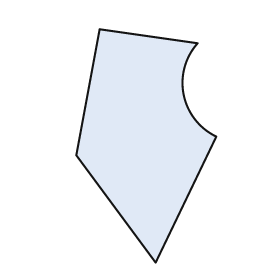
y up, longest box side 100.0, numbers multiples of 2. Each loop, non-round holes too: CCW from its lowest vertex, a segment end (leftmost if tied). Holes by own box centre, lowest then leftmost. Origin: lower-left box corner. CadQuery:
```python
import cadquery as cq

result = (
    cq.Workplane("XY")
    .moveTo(34.0, 0.0)
    .lineTo(60.0, 54.0)
    .threePointArc((46.0, 72.0), (52.0, 94.0))
    .lineTo(10.0, 100.0)
    .lineTo(0.0, 46.0)
    .close()
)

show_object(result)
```